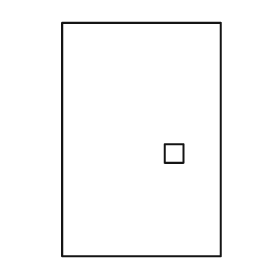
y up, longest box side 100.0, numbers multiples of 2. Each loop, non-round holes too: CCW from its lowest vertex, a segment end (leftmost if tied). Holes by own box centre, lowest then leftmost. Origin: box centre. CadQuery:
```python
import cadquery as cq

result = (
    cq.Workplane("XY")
    .moveTo(-34.0, -50.0)
    .lineTo(34.0, -50.0)
    .lineTo(34.0, 50.0)
    .lineTo(-34.0, 50.0)
    .close()
    .moveTo(10.0, -10.0)
    .lineTo(18.0, -10.0)
    .lineTo(18.0, -2.0)
    .lineTo(10.0, -2.0)
    .close()
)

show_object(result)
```